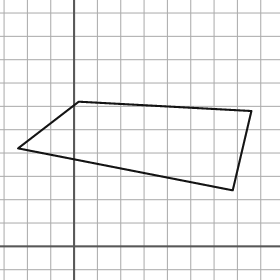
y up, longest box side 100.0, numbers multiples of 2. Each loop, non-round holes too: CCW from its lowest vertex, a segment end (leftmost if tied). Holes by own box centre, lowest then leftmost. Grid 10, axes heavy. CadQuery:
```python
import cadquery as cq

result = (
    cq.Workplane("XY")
    .moveTo(68.0, 24.0)
    .lineTo(76.0, 58.0)
    .lineTo(2.0, 62.0)
    .lineTo(-24.0, 42.0)
    .close()
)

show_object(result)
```